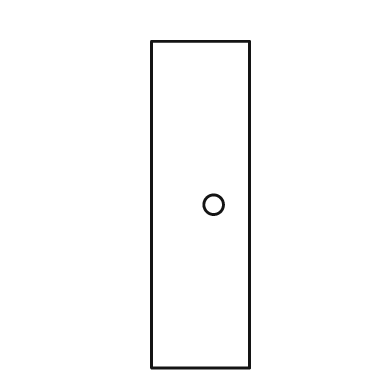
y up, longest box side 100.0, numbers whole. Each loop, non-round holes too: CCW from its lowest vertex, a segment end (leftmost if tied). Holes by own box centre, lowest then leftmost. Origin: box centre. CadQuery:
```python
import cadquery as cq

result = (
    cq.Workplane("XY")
    .moveTo(-15.0, -50.0)
    .lineTo(15.0, -50.0)
    .lineTo(15.0, 50.0)
    .lineTo(-15.0, 50.0)
    .close()
    .moveTo(4.0, 0.0)
    .circle(3.0)
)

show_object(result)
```